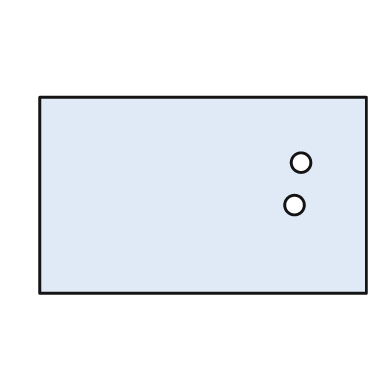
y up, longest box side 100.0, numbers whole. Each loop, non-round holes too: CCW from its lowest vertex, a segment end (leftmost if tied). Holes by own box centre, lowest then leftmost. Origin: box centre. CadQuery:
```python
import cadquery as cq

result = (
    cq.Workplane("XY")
    .moveTo(-50.0, -30.0)
    .lineTo(50.0, -30.0)
    .lineTo(50.0, 30.0)
    .lineTo(-50.0, 30.0)
    .close()
    .moveTo(28.0, -3.0)
    .circle(3.0)
    .moveTo(30.0, 10.0)
    .circle(3.0)
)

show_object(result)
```